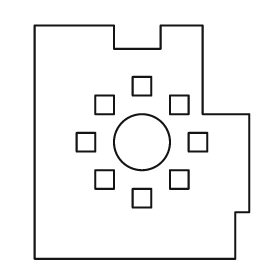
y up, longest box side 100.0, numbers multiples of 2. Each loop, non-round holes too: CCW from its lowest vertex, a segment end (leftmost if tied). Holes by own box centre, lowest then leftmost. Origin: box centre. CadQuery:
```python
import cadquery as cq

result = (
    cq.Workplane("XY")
    .moveTo(-46.0, -50.0)
    .lineTo(40.0, -50.0)
    .lineTo(40.0, -30.0)
    .lineTo(46.0, -30.0)
    .lineTo(46.0, 12.0)
    .lineTo(26.0, 12.0)
    .lineTo(26.0, 50.0)
    .lineTo(8.0, 50.0)
    .lineTo(8.0, 40.0)
    .lineTo(-12.0, 40.0)
    .lineTo(-12.0, 50.0)
    .lineTo(-46.0, 50.0)
    .close()
    .moveTo(-4.0, -28.0)
    .lineTo(4.0, -28.0)
    .lineTo(4.0, -20.0)
    .lineTo(-4.0, -20.0)
    .close()
    .moveTo(-20.0, -20.0)
    .lineTo(-12.0, -20.0)
    .lineTo(-12.0, -12.0)
    .lineTo(-20.0, -12.0)
    .close()
    .moveTo(12.0, -20.0)
    .lineTo(20.0, -20.0)
    .lineTo(20.0, -12.0)
    .lineTo(12.0, -12.0)
    .close()
    .moveTo(-28.0, -4.0)
    .lineTo(-20.0, -4.0)
    .lineTo(-20.0, 4.0)
    .lineTo(-28.0, 4.0)
    .close()
    .moveTo(0.0, 0.0)
    .circle(12.0)
    .moveTo(20.0, -4.0)
    .lineTo(28.0, -4.0)
    .lineTo(28.0, 4.0)
    .lineTo(20.0, 4.0)
    .close()
    .moveTo(-20.0, 12.0)
    .lineTo(-12.0, 12.0)
    .lineTo(-12.0, 20.0)
    .lineTo(-20.0, 20.0)
    .close()
    .moveTo(12.0, 12.0)
    .lineTo(20.0, 12.0)
    .lineTo(20.0, 20.0)
    .lineTo(12.0, 20.0)
    .close()
    .moveTo(-4.0, 20.0)
    .lineTo(4.0, 20.0)
    .lineTo(4.0, 28.0)
    .lineTo(-4.0, 28.0)
    .close()
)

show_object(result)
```